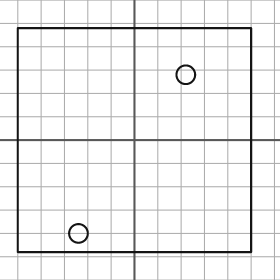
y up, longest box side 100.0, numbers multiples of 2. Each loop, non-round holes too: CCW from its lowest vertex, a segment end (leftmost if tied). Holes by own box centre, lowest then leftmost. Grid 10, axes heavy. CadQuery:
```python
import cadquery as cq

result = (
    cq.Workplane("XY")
    .moveTo(-50.0, -48.0)
    .lineTo(50.0, -48.0)
    .lineTo(50.0, 48.0)
    .lineTo(-50.0, 48.0)
    .close()
    .moveTo(-24.0, -40.0)
    .circle(4.0)
    .moveTo(22.0, 28.0)
    .circle(4.0)
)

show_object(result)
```